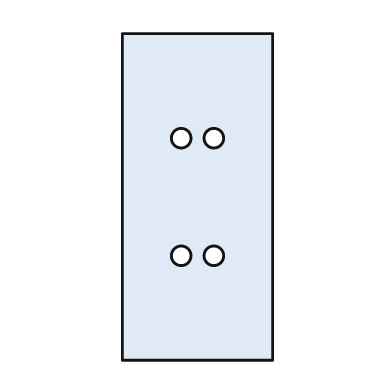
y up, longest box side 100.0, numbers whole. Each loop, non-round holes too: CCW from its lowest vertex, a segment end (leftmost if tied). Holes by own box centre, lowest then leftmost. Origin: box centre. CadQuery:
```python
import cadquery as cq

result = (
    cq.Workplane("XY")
    .moveTo(-23.0, -50.0)
    .lineTo(23.0, -50.0)
    .lineTo(23.0, 50.0)
    .lineTo(-23.0, 50.0)
    .close()
    .moveTo(-5.0, -18.0)
    .circle(3.0)
    .moveTo(5.0, -18.0)
    .circle(3.0)
    .moveTo(-5.0, 18.0)
    .circle(3.0)
    .moveTo(5.0, 18.0)
    .circle(3.0)
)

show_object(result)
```